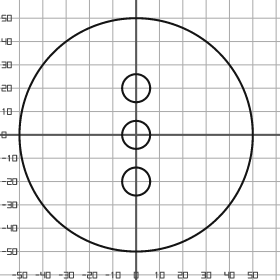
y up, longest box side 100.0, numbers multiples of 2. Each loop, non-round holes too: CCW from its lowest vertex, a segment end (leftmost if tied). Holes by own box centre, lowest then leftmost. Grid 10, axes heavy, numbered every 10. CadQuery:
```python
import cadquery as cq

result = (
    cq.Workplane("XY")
    .moveTo(0.0, 0.0)
    .circle(50.0)
    .moveTo(0.0, -20.0)
    .circle(6.0)
    .moveTo(0.0, 0.0)
    .circle(6.0)
    .moveTo(0.0, 20.0)
    .circle(6.0)
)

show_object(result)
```